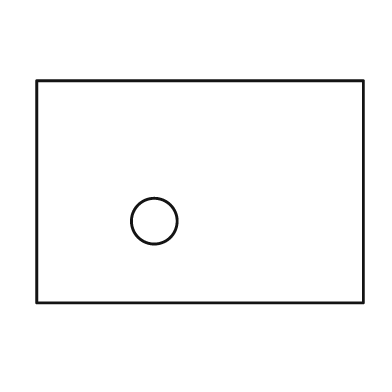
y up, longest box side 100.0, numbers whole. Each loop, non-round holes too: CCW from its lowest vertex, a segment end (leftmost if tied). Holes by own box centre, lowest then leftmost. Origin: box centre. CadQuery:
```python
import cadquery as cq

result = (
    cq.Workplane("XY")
    .moveTo(-50.0, -34.0)
    .lineTo(50.0, -34.0)
    .lineTo(50.0, 34.0)
    .lineTo(-50.0, 34.0)
    .close()
    .moveTo(-14.0, -9.0)
    .circle(7.0)
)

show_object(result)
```